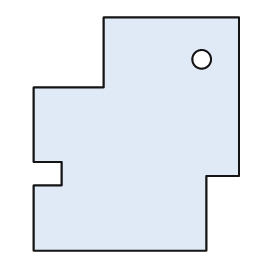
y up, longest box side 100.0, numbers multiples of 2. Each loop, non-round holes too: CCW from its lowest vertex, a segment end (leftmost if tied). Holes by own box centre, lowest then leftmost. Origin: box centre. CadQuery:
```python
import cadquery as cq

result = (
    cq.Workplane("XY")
    .moveTo(-44.0, -50.0)
    .lineTo(30.0, -50.0)
    .lineTo(30.0, -18.0)
    .lineTo(44.0, -18.0)
    .lineTo(44.0, 50.0)
    .lineTo(-14.0, 50.0)
    .lineTo(-14.0, 20.0)
    .lineTo(-44.0, 20.0)
    .lineTo(-44.0, -12.0)
    .lineTo(-32.0, -12.0)
    .lineTo(-32.0, -22.0)
    .lineTo(-44.0, -22.0)
    .close()
    .moveTo(28.0, 32.0)
    .circle(4.0)
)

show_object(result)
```